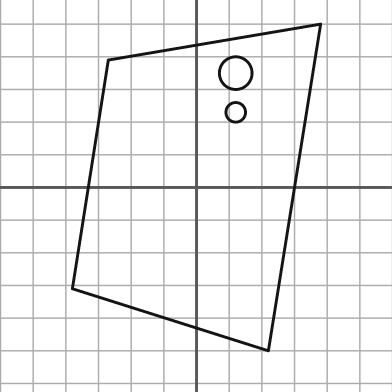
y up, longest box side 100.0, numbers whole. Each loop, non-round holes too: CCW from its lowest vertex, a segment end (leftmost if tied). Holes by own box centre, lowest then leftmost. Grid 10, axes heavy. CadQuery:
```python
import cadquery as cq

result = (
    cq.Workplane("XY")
    .moveTo(22.0, -50.0)
    .lineTo(38.0, 50.0)
    .lineTo(-27.0, 39.0)
    .lineTo(-38.0, -31.0)
    .close()
    .moveTo(12.0, 23.0)
    .circle(3.0)
    .moveTo(12.0, 35.0)
    .circle(5.0)
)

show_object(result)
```